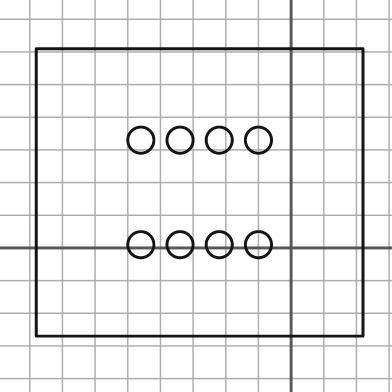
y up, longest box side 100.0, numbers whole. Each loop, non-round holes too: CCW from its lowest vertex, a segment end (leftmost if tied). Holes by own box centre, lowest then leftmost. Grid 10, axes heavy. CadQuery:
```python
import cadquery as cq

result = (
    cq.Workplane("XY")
    .moveTo(-78.0, -27.0)
    .lineTo(22.0, -27.0)
    .lineTo(22.0, 61.0)
    .lineTo(-78.0, 61.0)
    .close()
    .moveTo(-46.0, 1.0)
    .circle(4.0)
    .moveTo(-34.0, 1.0)
    .circle(4.0)
    .moveTo(-22.0, 1.0)
    .circle(4.0)
    .moveTo(-10.0, 1.0)
    .circle(4.0)
    .moveTo(-46.0, 33.0)
    .circle(4.0)
    .moveTo(-34.0, 33.0)
    .circle(4.0)
    .moveTo(-22.0, 33.0)
    .circle(4.0)
    .moveTo(-10.0, 33.0)
    .circle(4.0)
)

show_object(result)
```